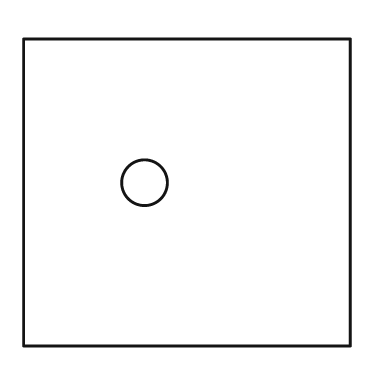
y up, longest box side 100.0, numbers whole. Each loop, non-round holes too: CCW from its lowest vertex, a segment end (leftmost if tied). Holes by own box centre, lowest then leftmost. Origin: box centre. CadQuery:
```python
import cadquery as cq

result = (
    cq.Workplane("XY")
    .moveTo(-50.0, -47.0)
    .lineTo(50.0, -47.0)
    .lineTo(50.0, 47.0)
    .lineTo(-50.0, 47.0)
    .close()
    .moveTo(-13.0, 3.0)
    .circle(7.0)
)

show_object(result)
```